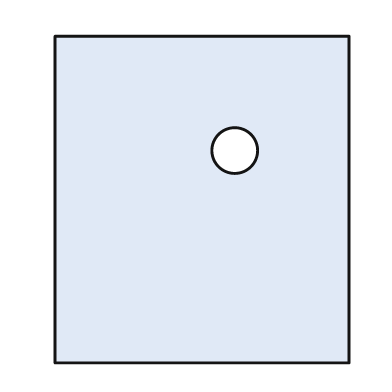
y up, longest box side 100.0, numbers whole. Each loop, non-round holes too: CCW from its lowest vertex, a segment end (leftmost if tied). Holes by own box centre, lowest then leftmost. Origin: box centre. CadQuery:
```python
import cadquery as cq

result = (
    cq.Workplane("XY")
    .moveTo(-45.0, -50.0)
    .lineTo(45.0, -50.0)
    .lineTo(45.0, 50.0)
    .lineTo(-45.0, 50.0)
    .close()
    .moveTo(10.0, 15.0)
    .circle(7.0)
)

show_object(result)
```